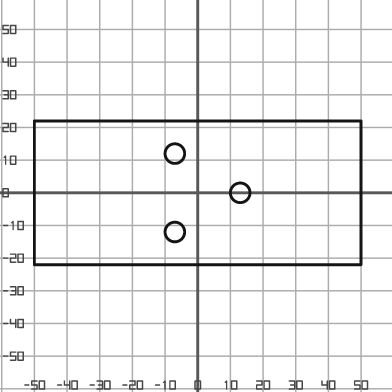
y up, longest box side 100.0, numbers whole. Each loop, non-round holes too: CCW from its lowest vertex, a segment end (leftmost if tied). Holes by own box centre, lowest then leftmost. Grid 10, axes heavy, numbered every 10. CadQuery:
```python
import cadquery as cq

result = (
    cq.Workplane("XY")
    .moveTo(-50.0, -22.0)
    .lineTo(50.0, -22.0)
    .lineTo(50.0, 22.0)
    .lineTo(-50.0, 22.0)
    .close()
    .moveTo(-7.0, -12.0)
    .circle(3.0)
    .moveTo(13.0, 0.0)
    .circle(3.0)
    .moveTo(-7.0, 12.0)
    .circle(3.0)
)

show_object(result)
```